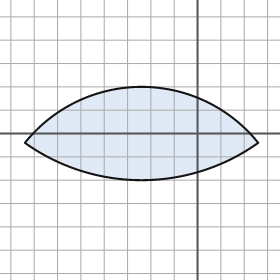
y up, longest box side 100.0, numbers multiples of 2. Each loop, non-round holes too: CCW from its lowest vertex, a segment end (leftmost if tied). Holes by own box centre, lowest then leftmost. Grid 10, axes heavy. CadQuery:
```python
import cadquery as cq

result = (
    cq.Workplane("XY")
    .moveTo(-74.0, -4.0)
    .threePointArc((-24.0, -20.0), (26.0, -4.0))
    .threePointArc((-24.0, 20.0), (-74.0, -4.0))
    .close()
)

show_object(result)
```